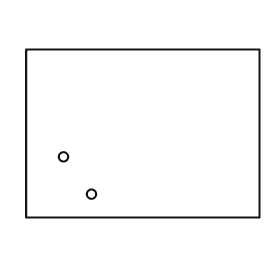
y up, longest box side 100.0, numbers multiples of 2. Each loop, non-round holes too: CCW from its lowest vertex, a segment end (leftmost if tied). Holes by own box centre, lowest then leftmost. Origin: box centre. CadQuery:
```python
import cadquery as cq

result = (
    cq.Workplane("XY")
    .moveTo(-50.0, -36.0)
    .lineTo(50.0, -36.0)
    .lineTo(50.0, 36.0)
    .lineTo(-50.0, 36.0)
    .close()
    .moveTo(-22.0, -26.0)
    .circle(2.0)
    .moveTo(-34.0, -10.0)
    .circle(2.0)
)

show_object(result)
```